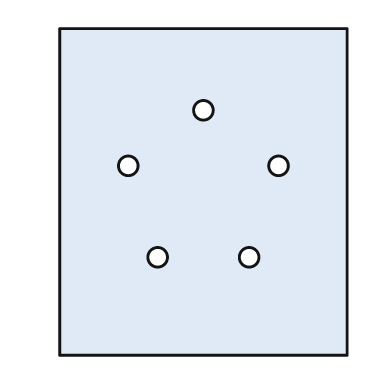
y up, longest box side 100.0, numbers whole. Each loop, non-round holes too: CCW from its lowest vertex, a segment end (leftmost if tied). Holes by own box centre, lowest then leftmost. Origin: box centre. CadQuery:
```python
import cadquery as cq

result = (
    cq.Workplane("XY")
    .moveTo(-44.0, -50.0)
    .lineTo(44.0, -50.0)
    .lineTo(44.0, 50.0)
    .lineTo(-44.0, 50.0)
    .close()
    .moveTo(-14.0, -20.0)
    .circle(3.0)
    .moveTo(14.0, -20.0)
    .circle(3.0)
    .moveTo(-23.0, 8.0)
    .circle(3.0)
    .moveTo(23.0, 8.0)
    .circle(3.0)
    .moveTo(0.0, 25.0)
    .circle(3.0)
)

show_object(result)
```